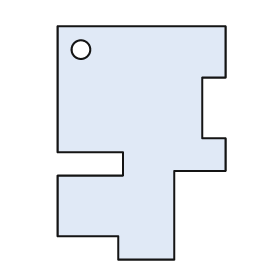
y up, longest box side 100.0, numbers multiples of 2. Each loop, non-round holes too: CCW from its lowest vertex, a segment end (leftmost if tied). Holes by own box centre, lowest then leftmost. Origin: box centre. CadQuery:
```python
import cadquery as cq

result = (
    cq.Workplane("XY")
    .moveTo(-10.0, -50.0)
    .lineTo(14.0, -50.0)
    .lineTo(14.0, -12.0)
    .lineTo(36.0, -12.0)
    .lineTo(36.0, 2.0)
    .lineTo(26.0, 2.0)
    .lineTo(26.0, 28.0)
    .lineTo(36.0, 28.0)
    .lineTo(36.0, 50.0)
    .lineTo(-36.0, 50.0)
    .lineTo(-36.0, -4.0)
    .lineTo(-8.0, -4.0)
    .lineTo(-8.0, -14.0)
    .lineTo(-36.0, -14.0)
    .lineTo(-36.0, -40.0)
    .lineTo(-10.0, -40.0)
    .close()
    .moveTo(-26.0, 40.0)
    .circle(4.0)
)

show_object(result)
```